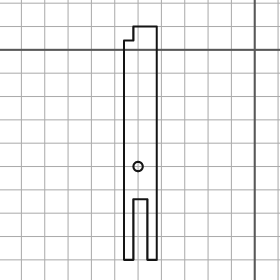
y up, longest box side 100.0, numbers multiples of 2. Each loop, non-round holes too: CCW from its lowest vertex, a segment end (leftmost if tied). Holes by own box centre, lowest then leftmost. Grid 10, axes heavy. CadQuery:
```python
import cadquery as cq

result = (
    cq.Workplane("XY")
    .moveTo(-56.0, -90.0)
    .lineTo(-52.0, -90.0)
    .lineTo(-52.0, -64.0)
    .lineTo(-46.0, -64.0)
    .lineTo(-46.0, -90.0)
    .lineTo(-42.0, -90.0)
    .lineTo(-42.0, 10.0)
    .lineTo(-52.0, 10.0)
    .lineTo(-52.0, 4.0)
    .lineTo(-56.0, 4.0)
    .close()
    .moveTo(-50.0, -50.0)
    .circle(2.0)
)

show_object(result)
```